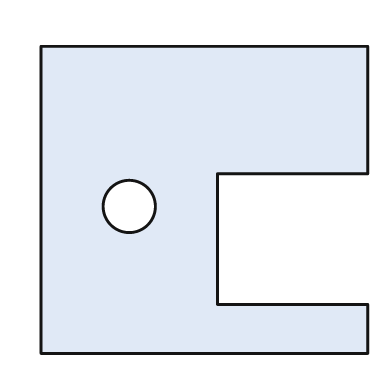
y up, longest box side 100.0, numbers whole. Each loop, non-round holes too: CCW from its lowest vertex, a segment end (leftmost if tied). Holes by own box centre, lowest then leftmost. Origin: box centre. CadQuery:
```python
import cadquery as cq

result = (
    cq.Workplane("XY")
    .moveTo(-50.0, -47.0)
    .lineTo(50.0, -47.0)
    .lineTo(50.0, -32.0)
    .lineTo(4.0, -32.0)
    .lineTo(4.0, 8.0)
    .lineTo(50.0, 8.0)
    .lineTo(50.0, 47.0)
    .lineTo(-50.0, 47.0)
    .close()
    .moveTo(-23.0, -2.0)
    .circle(8.0)
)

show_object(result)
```